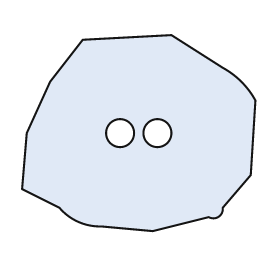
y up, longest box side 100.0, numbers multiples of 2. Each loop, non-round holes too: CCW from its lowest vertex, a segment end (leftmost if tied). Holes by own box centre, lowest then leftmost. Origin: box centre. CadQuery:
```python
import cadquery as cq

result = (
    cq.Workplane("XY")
    .moveTo(6.0, -42.0)
    .lineTo(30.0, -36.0)
    .threePointArc((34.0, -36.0), (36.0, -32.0))
    .lineTo(48.0, -18.0)
    .lineTo(50.0, 14.0)
    .threePointArc((44.0, 22.0), (36.0, 28.0))
    .lineTo(14.0, 42.0)
    .lineTo(-24.0, 40.0)
    .lineTo(-38.0, 22.0)
    .lineTo(-48.0, 0.0)
    .lineTo(-50.0, -24.0)
    .lineTo(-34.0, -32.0)
    .threePointArc((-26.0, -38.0), (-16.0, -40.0))
    .close()
    .moveTo(-8.0, 0.0)
    .circle(6.0)
    .moveTo(8.0, 0.0)
    .circle(6.0)
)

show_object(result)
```